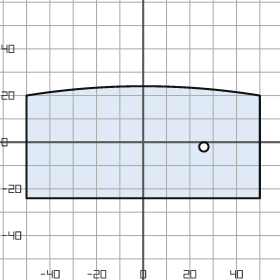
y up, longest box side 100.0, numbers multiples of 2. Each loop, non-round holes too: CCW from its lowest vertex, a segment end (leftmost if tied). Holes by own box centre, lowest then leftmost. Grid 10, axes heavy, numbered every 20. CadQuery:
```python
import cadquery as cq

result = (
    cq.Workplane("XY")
    .moveTo(-50.0, -24.0)
    .lineTo(50.0, -24.0)
    .lineTo(50.0, 20.0)
    .threePointArc((0.0, 24.0), (-50.0, 20.0))
    .close()
    .moveTo(26.0, -2.0)
    .circle(2.0)
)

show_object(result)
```